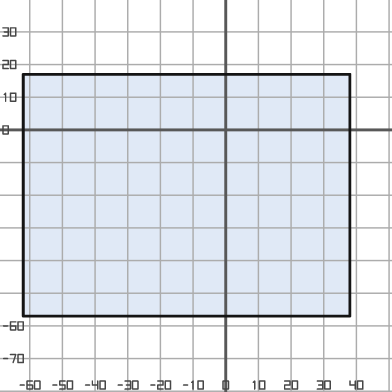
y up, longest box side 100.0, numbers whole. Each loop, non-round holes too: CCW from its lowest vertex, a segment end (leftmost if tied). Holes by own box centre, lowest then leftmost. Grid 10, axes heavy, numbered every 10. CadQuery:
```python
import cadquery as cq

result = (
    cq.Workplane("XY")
    .moveTo(-62.0, -57.0)
    .lineTo(38.0, -57.0)
    .lineTo(38.0, 17.0)
    .lineTo(-62.0, 17.0)
    .close()
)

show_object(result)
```